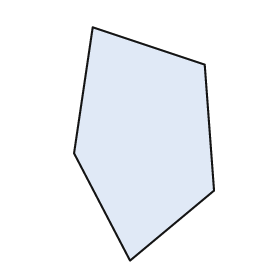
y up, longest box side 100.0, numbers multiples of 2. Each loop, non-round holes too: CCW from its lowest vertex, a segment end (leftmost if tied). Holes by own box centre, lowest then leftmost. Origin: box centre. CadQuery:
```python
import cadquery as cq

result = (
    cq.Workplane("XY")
    .moveTo(-6.0, -50.0)
    .lineTo(30.0, -20.0)
    .lineTo(26.0, 34.0)
    .lineTo(-22.0, 50.0)
    .lineTo(-30.0, -4.0)
    .close()
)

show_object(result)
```